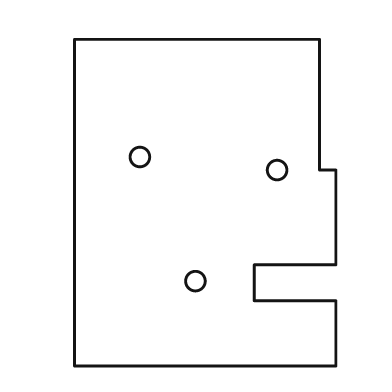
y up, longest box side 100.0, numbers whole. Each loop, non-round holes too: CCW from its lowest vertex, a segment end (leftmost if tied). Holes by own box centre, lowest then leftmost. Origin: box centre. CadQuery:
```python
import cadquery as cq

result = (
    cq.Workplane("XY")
    .moveTo(-40.0, -50.0)
    .lineTo(40.0, -50.0)
    .lineTo(40.0, -30.0)
    .lineTo(15.0, -30.0)
    .lineTo(15.0, -19.0)
    .lineTo(40.0, -19.0)
    .lineTo(40.0, 10.0)
    .lineTo(35.0, 10.0)
    .lineTo(35.0, 50.0)
    .lineTo(-40.0, 50.0)
    .close()
    .moveTo(-3.0, -24.0)
    .circle(3.0)
    .moveTo(22.0, 10.0)
    .circle(3.0)
    .moveTo(-20.0, 14.0)
    .circle(3.0)
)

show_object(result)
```